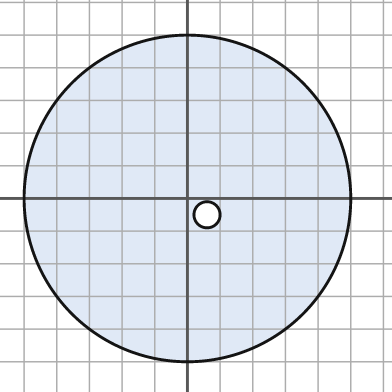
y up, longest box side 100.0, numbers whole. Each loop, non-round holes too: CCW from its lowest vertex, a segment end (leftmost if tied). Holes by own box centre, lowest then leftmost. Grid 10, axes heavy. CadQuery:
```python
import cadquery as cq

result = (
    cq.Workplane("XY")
    .moveTo(0.0, 0.0)
    .circle(50.0)
    .moveTo(6.0, -5.0)
    .circle(4.0)
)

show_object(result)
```